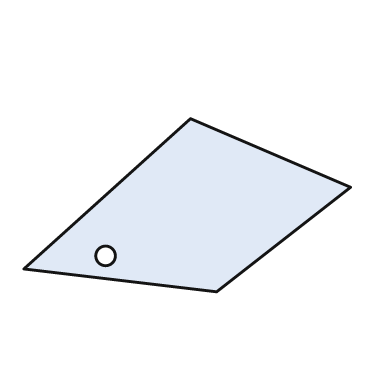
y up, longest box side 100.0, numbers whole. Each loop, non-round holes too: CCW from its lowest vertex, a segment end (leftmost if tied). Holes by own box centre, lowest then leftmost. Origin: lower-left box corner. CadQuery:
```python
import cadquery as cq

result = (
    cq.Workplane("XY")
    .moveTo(59.0, 0.0)
    .lineTo(100.0, 32.0)
    .lineTo(51.0, 53.0)
    .lineTo(0.0, 7.0)
    .close()
    .moveTo(25.0, 11.0)
    .circle(3.0)
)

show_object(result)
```